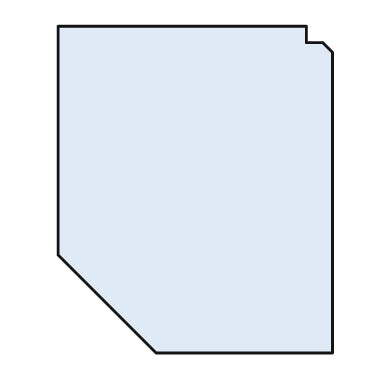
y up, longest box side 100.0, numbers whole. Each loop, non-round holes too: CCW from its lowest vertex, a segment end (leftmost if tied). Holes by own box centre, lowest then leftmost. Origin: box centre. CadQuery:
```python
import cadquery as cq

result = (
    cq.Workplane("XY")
    .moveTo(-12.0, -50.0)
    .lineTo(42.0, -50.0)
    .lineTo(42.0, 42.0)
    .lineTo(39.0, 45.0)
    .lineTo(34.0, 45.0)
    .lineTo(34.0, 50.0)
    .lineTo(-42.0, 50.0)
    .lineTo(-42.0, -20.0)
    .close()
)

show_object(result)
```